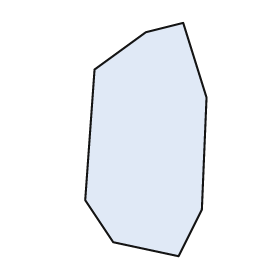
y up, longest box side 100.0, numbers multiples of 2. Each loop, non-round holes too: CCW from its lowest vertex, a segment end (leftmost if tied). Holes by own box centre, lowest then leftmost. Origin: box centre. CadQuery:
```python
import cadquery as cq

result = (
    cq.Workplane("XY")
    .moveTo(14.0, -50.0)
    .lineTo(24.0, -30.0)
    .lineTo(26.0, 18.0)
    .lineTo(16.0, 50.0)
    .lineTo(0.0, 46.0)
    .lineTo(-22.0, 30.0)
    .lineTo(-26.0, -26.0)
    .lineTo(-14.0, -44.0)
    .close()
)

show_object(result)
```